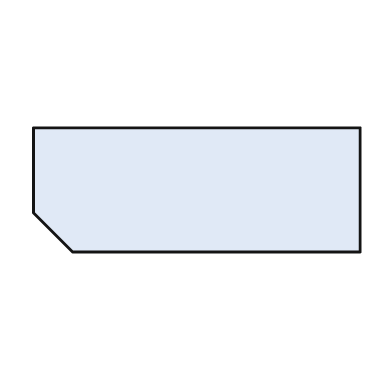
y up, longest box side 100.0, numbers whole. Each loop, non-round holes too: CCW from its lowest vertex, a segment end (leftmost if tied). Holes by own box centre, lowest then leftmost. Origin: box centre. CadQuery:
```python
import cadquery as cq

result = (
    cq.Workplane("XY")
    .moveTo(-38.0, -19.0)
    .lineTo(50.0, -19.0)
    .lineTo(50.0, 19.0)
    .lineTo(-50.0, 19.0)
    .lineTo(-50.0, -7.0)
    .close()
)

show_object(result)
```